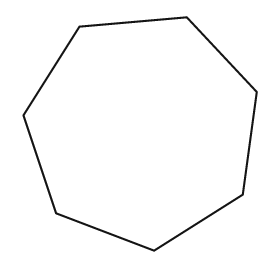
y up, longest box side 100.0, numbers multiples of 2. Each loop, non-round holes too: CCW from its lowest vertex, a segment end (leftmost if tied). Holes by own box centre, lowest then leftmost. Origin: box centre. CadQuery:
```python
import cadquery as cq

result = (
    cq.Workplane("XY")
    .moveTo(6.0, -50.0)
    .lineTo(44.0, -26.0)
    .lineTo(50.0, 18.0)
    .lineTo(20.0, 50.0)
    .lineTo(-26.0, 46.0)
    .lineTo(-50.0, 8.0)
    .lineTo(-36.0, -34.0)
    .close()
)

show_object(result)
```